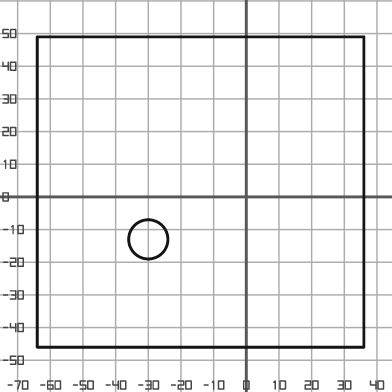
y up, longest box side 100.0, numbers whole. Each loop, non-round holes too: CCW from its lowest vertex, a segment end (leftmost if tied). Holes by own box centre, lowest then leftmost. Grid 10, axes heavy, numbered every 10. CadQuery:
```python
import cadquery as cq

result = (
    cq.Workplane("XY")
    .moveTo(-64.0, -46.0)
    .lineTo(36.0, -46.0)
    .lineTo(36.0, 49.0)
    .lineTo(-64.0, 49.0)
    .close()
    .moveTo(-30.0, -13.0)
    .circle(6.0)
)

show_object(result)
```